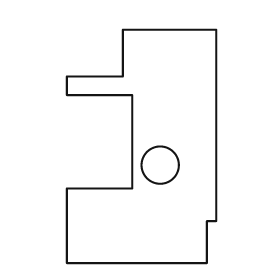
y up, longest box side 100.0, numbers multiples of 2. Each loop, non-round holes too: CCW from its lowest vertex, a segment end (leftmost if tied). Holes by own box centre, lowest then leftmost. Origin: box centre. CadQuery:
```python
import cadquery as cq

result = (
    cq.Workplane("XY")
    .moveTo(-32.0, -50.0)
    .lineTo(28.0, -50.0)
    .lineTo(28.0, -32.0)
    .lineTo(32.0, -32.0)
    .lineTo(32.0, 50.0)
    .lineTo(-8.0, 50.0)
    .lineTo(-8.0, 30.0)
    .lineTo(-32.0, 30.0)
    .lineTo(-32.0, 22.0)
    .lineTo(-4.0, 22.0)
    .lineTo(-4.0, -18.0)
    .lineTo(-32.0, -18.0)
    .close()
    .moveTo(8.0, -8.0)
    .circle(8.0)
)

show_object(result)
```